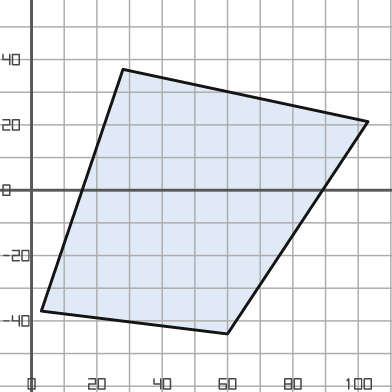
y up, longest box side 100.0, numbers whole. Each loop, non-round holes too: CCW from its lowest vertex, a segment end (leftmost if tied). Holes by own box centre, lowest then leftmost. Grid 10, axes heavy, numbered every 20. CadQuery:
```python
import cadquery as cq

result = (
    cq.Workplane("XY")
    .moveTo(60.0, -44.0)
    .lineTo(103.0, 21.0)
    .lineTo(28.0, 37.0)
    .lineTo(3.0, -37.0)
    .close()
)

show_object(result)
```